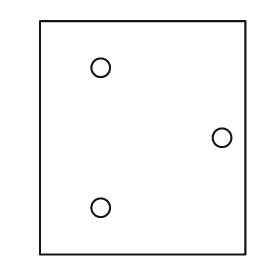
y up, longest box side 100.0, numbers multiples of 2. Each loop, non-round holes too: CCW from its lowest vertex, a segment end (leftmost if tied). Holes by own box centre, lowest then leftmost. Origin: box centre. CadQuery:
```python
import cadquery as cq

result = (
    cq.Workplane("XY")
    .moveTo(-44.0, -50.0)
    .lineTo(44.0, -50.0)
    .lineTo(44.0, 50.0)
    .lineTo(-44.0, 50.0)
    .close()
    .moveTo(-18.0, -30.0)
    .circle(4.0)
    .moveTo(34.0, 0.0)
    .circle(4.0)
    .moveTo(-18.0, 30.0)
    .circle(4.0)
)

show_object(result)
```